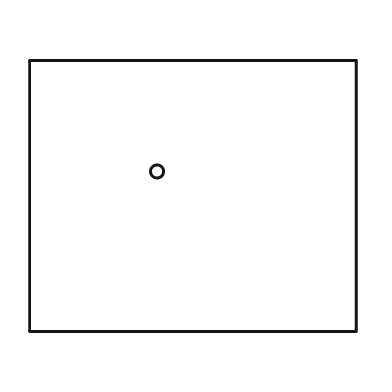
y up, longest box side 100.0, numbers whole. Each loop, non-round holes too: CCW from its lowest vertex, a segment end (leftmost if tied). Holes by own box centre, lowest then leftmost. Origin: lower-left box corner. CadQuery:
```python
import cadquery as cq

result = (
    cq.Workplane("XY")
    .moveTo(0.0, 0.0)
    .lineTo(100.0, 0.0)
    .lineTo(100.0, 83.0)
    .lineTo(0.0, 83.0)
    .close()
    .moveTo(39.0, 49.0)
    .circle(2.0)
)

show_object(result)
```